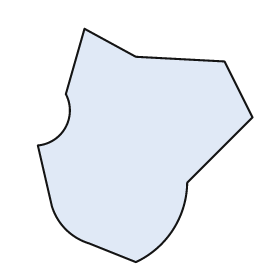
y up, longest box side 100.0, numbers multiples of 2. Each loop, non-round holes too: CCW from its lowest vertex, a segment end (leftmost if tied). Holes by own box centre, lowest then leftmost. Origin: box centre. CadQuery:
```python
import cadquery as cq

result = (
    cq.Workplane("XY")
    .moveTo(-4.0, -50.0)
    .threePointArc((12.0, -36.0), (18.0, -16.0))
    .lineTo(46.0, 12.0)
    .lineTo(34.0, 36.0)
    .lineTo(-4.0, 38.0)
    .lineTo(-26.0, 50.0)
    .lineTo(-34.0, 22.0)
    .threePointArc((-34.0, 8.0), (-46.0, 0.0))
    .lineTo(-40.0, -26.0)
    .threePointArc((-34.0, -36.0), (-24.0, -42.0))
    .close()
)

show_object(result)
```